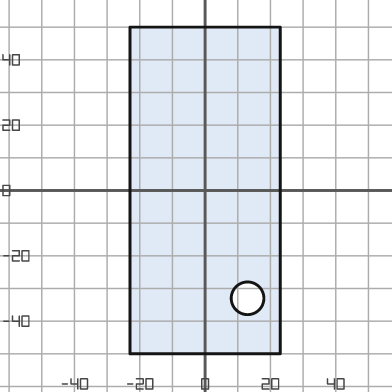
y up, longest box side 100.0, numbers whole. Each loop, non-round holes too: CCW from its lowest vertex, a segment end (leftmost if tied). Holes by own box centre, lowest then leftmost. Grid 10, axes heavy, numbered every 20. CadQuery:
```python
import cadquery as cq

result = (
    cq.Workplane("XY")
    .moveTo(-23.0, -50.0)
    .lineTo(23.0, -50.0)
    .lineTo(23.0, 50.0)
    .lineTo(-23.0, 50.0)
    .close()
    .moveTo(13.0, -33.0)
    .circle(5.0)
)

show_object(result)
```